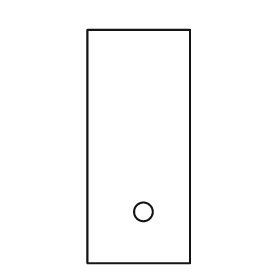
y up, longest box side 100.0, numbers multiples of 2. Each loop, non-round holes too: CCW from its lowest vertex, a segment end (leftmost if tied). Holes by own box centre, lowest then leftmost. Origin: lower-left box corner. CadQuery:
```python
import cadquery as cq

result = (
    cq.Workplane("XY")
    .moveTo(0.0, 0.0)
    .lineTo(44.0, 0.0)
    .lineTo(44.0, 100.0)
    .lineTo(0.0, 100.0)
    .close()
    .moveTo(24.0, 22.0)
    .circle(4.0)
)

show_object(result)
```